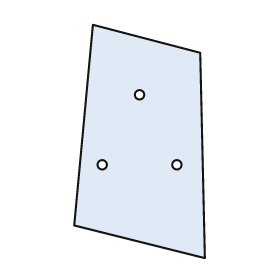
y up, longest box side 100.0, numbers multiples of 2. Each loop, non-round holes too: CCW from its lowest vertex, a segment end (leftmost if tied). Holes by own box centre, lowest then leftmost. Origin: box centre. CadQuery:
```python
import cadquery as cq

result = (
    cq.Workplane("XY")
    .moveTo(28.0, -50.0)
    .lineTo(26.0, 38.0)
    .lineTo(-20.0, 50.0)
    .lineTo(-28.0, -36.0)
    .close()
    .moveTo(-16.0, -10.0)
    .circle(2.0)
    .moveTo(16.0, -10.0)
    .circle(2.0)
    .moveTo(0.0, 20.0)
    .circle(2.0)
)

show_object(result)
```